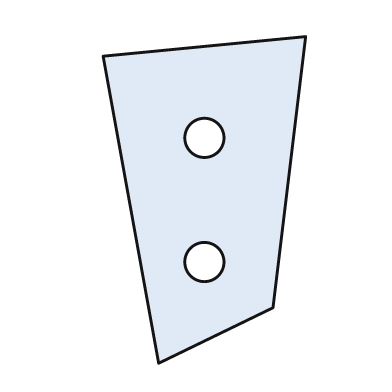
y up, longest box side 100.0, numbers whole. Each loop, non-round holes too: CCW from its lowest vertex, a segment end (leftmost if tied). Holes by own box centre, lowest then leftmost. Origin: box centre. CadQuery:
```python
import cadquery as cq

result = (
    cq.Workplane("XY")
    .moveTo(-14.0, -50.0)
    .lineTo(21.0, -33.0)
    .lineTo(31.0, 50.0)
    .lineTo(-31.0, 44.0)
    .close()
    .moveTo(0.0, -19.0)
    .circle(6.0)
    .moveTo(0.0, 19.0)
    .circle(6.0)
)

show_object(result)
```